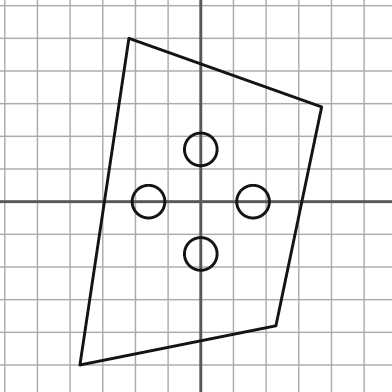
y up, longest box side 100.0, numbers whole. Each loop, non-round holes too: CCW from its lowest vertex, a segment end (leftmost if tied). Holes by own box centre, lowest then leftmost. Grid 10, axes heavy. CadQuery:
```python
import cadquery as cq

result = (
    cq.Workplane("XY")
    .moveTo(-37.0, -50.0)
    .lineTo(23.0, -38.0)
    .lineTo(37.0, 29.0)
    .lineTo(-22.0, 50.0)
    .close()
    .moveTo(0.0, -16.0)
    .circle(5.0)
    .moveTo(-16.0, 0.0)
    .circle(5.0)
    .moveTo(16.0, 0.0)
    .circle(5.0)
    .moveTo(0.0, 16.0)
    .circle(5.0)
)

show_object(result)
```